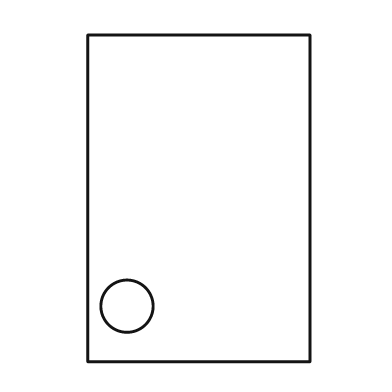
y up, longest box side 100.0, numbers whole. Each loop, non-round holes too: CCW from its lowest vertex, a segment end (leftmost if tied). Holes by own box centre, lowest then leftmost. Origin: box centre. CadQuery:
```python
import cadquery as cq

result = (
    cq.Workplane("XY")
    .moveTo(-34.0, -50.0)
    .lineTo(34.0, -50.0)
    .lineTo(34.0, 50.0)
    .lineTo(-34.0, 50.0)
    .close()
    .moveTo(-22.0, -33.0)
    .circle(8.0)
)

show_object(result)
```